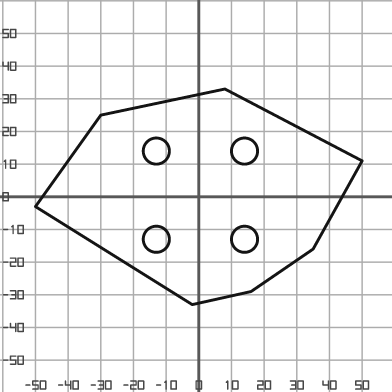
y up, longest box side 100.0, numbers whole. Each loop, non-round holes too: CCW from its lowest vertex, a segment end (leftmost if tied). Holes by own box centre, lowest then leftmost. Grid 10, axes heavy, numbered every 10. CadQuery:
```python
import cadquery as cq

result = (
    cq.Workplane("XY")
    .moveTo(-2.0, -33.0)
    .lineTo(16.0, -29.0)
    .lineTo(35.0, -16.0)
    .lineTo(50.0, 11.0)
    .lineTo(8.0, 33.0)
    .lineTo(-30.0, 25.0)
    .lineTo(-50.0, -3.0)
    .close()
    .moveTo(-13.0, -13.0)
    .circle(4.0)
    .moveTo(14.0, -13.0)
    .circle(4.0)
    .moveTo(-13.0, 14.0)
    .circle(4.0)
    .moveTo(14.0, 14.0)
    .circle(4.0)
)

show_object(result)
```